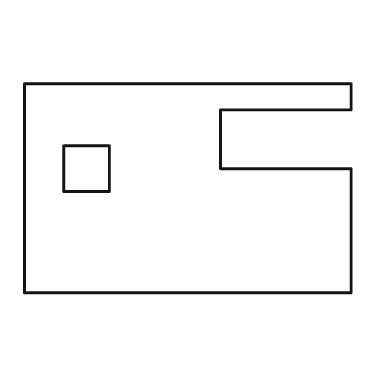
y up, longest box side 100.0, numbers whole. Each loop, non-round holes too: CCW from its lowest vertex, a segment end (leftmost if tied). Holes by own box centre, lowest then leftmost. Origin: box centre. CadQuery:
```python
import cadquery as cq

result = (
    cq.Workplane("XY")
    .moveTo(-50.0, -32.0)
    .lineTo(50.0, -32.0)
    .lineTo(50.0, 6.0)
    .lineTo(10.0, 6.0)
    .lineTo(10.0, 24.0)
    .lineTo(50.0, 24.0)
    .lineTo(50.0, 32.0)
    .lineTo(-50.0, 32.0)
    .close()
    .moveTo(-38.0, -1.0)
    .lineTo(-24.0, -1.0)
    .lineTo(-24.0, 13.0)
    .lineTo(-38.0, 13.0)
    .close()
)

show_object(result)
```